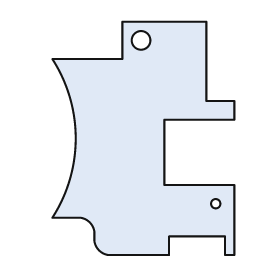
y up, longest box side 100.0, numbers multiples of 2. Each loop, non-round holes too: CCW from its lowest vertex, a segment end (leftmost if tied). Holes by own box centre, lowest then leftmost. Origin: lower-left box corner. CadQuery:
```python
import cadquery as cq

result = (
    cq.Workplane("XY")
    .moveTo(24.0, 0.0)
    .lineTo(50.0, 0.0)
    .lineTo(50.0, 8.0)
    .lineTo(74.0, 8.0)
    .lineTo(74.0, 0.0)
    .lineTo(78.0, 0.0)
    .lineTo(78.0, 30.0)
    .lineTo(48.0, 30.0)
    .lineTo(48.0, 58.0)
    .lineTo(78.0, 58.0)
    .lineTo(78.0, 66.0)
    .lineTo(66.0, 66.0)
    .lineTo(66.0, 100.0)
    .lineTo(30.0, 100.0)
    .lineTo(30.0, 84.0)
    .lineTo(0.0, 84.0)
    .threePointArc((10.0, 50.0), (0.0, 16.0))
    .lineTo(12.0, 16.0)
    .threePointArc((16.0, 14.0), (18.0, 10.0))
    .lineTo(18.0, 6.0)
    .threePointArc((20.0, 2.0), (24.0, 0.0))
    .close()
    .moveTo(70.0, 22.0)
    .circle(2.0)
    .moveTo(38.0, 92.0)
    .circle(4.0)
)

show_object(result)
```